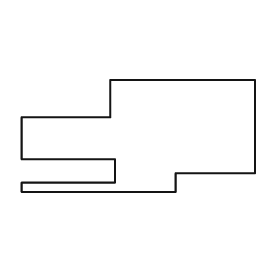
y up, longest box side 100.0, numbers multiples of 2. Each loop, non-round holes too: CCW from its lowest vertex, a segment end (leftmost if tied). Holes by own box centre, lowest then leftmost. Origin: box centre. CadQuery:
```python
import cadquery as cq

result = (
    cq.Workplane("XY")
    .moveTo(-50.0, -24.0)
    .lineTo(16.0, -24.0)
    .lineTo(16.0, -16.0)
    .lineTo(50.0, -16.0)
    .lineTo(50.0, 24.0)
    .lineTo(-12.0, 24.0)
    .lineTo(-12.0, 8.0)
    .lineTo(-50.0, 8.0)
    .lineTo(-50.0, -10.0)
    .lineTo(-10.0, -10.0)
    .lineTo(-10.0, -20.0)
    .lineTo(-50.0, -20.0)
    .close()
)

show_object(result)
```